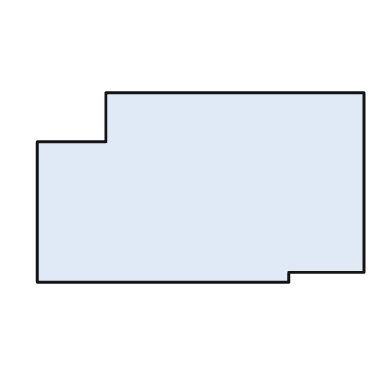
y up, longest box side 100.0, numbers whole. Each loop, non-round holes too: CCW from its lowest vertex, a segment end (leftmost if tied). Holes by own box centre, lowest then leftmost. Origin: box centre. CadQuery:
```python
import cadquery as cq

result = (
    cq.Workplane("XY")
    .moveTo(-50.0, -29.0)
    .lineTo(27.0, -29.0)
    .lineTo(27.0, -26.0)
    .lineTo(50.0, -26.0)
    .lineTo(50.0, 29.0)
    .lineTo(-29.0, 29.0)
    .lineTo(-29.0, 14.0)
    .lineTo(-50.0, 14.0)
    .close()
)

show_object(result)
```